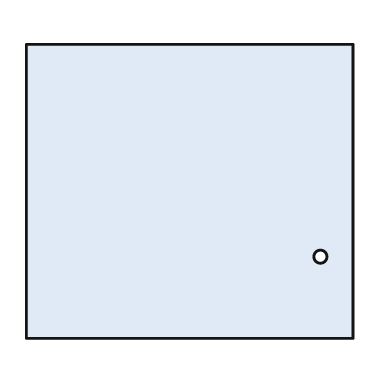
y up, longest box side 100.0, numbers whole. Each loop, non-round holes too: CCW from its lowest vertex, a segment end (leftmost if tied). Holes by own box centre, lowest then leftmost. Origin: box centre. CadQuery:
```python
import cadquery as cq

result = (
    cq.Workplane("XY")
    .moveTo(-50.0, -45.0)
    .lineTo(50.0, -45.0)
    .lineTo(50.0, 45.0)
    .lineTo(-50.0, 45.0)
    .close()
    .moveTo(40.0, -20.0)
    .circle(2.0)
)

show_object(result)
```